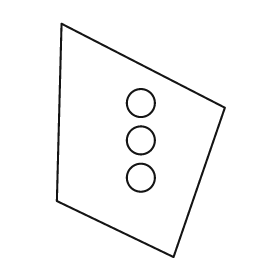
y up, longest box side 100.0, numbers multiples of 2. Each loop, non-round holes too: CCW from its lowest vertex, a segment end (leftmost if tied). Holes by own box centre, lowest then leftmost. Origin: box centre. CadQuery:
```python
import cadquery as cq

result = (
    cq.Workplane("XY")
    .moveTo(14.0, -50.0)
    .lineTo(36.0, 14.0)
    .lineTo(-34.0, 50.0)
    .lineTo(-36.0, -26.0)
    .close()
    .moveTo(0.0, -16.0)
    .circle(6.0)
    .moveTo(0.0, 0.0)
    .circle(6.0)
    .moveTo(0.0, 16.0)
    .circle(6.0)
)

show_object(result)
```